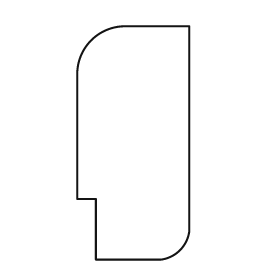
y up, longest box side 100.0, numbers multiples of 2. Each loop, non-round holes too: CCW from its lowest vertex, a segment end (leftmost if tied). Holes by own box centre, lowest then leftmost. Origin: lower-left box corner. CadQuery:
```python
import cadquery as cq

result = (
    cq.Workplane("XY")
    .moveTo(8.0, 0.0)
    .lineTo(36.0, 0.0)
    .threePointArc((44.0, 4.0), (48.0, 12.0))
    .lineTo(48.0, 100.0)
    .lineTo(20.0, 100.0)
    .threePointArc((6.0, 94.0), (0.0, 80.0))
    .lineTo(0.0, 26.0)
    .lineTo(8.0, 26.0)
    .close()
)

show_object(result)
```